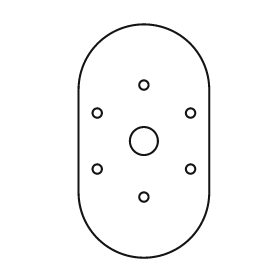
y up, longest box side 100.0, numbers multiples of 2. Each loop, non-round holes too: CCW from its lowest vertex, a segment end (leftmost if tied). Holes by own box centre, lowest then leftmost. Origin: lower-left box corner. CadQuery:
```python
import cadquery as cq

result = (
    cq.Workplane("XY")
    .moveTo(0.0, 28.0)
    .threePointArc((28.0, 0.0), (56.0, 28.0))
    .lineTo(56.0, 72.0)
    .threePointArc((28.0, 100.0), (0.0, 72.0))
    .close()
    .moveTo(28.0, 26.0)
    .circle(2.0)
    .moveTo(8.0, 38.0)
    .circle(2.0)
    .moveTo(48.0, 38.0)
    .circle(2.0)
    .moveTo(28.0, 50.0)
    .circle(6.0)
    .moveTo(8.0, 62.0)
    .circle(2.0)
    .moveTo(48.0, 62.0)
    .circle(2.0)
    .moveTo(28.0, 74.0)
    .circle(2.0)
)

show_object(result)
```